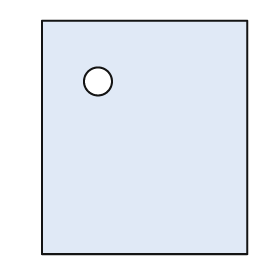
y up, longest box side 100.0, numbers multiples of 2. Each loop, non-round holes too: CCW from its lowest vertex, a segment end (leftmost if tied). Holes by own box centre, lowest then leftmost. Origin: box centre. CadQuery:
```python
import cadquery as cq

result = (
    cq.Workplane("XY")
    .moveTo(-44.0, -50.0)
    .lineTo(44.0, -50.0)
    .lineTo(44.0, 50.0)
    .lineTo(-44.0, 50.0)
    .close()
    .moveTo(-20.0, 24.0)
    .circle(6.0)
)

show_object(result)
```